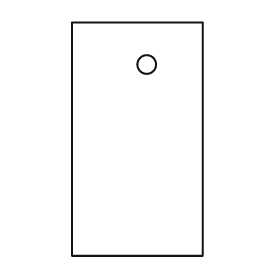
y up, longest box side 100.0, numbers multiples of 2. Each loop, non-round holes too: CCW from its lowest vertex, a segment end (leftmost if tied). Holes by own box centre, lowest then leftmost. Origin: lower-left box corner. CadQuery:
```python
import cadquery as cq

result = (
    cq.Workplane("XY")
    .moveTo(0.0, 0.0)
    .lineTo(56.0, 0.0)
    .lineTo(56.0, 100.0)
    .lineTo(0.0, 100.0)
    .close()
    .moveTo(32.0, 82.0)
    .circle(4.0)
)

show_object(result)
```